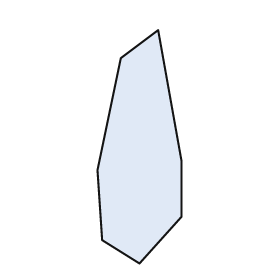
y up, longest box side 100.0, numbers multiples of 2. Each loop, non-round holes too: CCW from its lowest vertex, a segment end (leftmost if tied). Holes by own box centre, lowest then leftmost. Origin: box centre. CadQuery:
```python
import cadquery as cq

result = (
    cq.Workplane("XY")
    .moveTo(0.0, -50.0)
    .lineTo(18.0, -30.0)
    .lineTo(18.0, -6.0)
    .lineTo(8.0, 50.0)
    .lineTo(-8.0, 38.0)
    .lineTo(-18.0, -10.0)
    .lineTo(-16.0, -40.0)
    .close()
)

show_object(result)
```